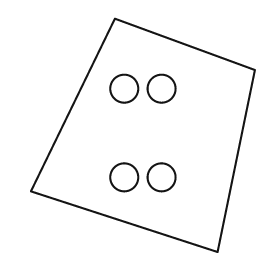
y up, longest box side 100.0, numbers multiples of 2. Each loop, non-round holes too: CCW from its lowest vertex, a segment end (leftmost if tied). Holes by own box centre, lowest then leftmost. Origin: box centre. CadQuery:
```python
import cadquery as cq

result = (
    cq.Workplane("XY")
    .moveTo(32.0, -50.0)
    .lineTo(48.0, 28.0)
    .lineTo(-12.0, 50.0)
    .lineTo(-48.0, -24.0)
    .close()
    .moveTo(-8.0, -18.0)
    .circle(6.0)
    .moveTo(8.0, -18.0)
    .circle(6.0)
    .moveTo(-8.0, 20.0)
    .circle(6.0)
    .moveTo(8.0, 20.0)
    .circle(6.0)
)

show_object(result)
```